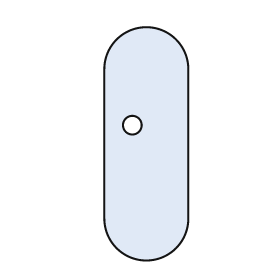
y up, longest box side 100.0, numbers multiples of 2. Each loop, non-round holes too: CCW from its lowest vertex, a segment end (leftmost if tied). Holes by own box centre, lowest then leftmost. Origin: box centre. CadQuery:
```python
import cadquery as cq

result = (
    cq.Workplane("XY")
    .moveTo(-18.0, -32.0)
    .threePointArc((0.0, -50.0), (18.0, -32.0))
    .lineTo(18.0, 32.0)
    .threePointArc((0.0, 50.0), (-18.0, 32.0))
    .close()
    .moveTo(-6.0, 8.0)
    .circle(4.0)
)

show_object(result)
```